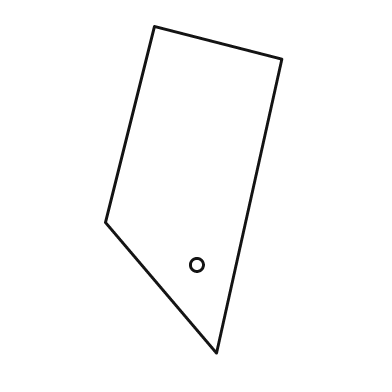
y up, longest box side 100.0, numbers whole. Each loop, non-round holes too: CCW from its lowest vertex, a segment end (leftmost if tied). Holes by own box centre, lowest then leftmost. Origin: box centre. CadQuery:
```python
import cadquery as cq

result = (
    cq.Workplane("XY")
    .moveTo(7.0, -50.0)
    .lineTo(27.0, 40.0)
    .lineTo(-12.0, 50.0)
    .lineTo(-27.0, -10.0)
    .close()
    .moveTo(1.0, -23.0)
    .circle(2.0)
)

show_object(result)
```